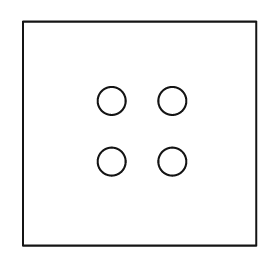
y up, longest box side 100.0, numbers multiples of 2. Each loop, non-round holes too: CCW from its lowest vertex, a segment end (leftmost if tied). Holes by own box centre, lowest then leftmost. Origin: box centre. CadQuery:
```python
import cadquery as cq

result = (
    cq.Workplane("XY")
    .moveTo(-50.0, -48.0)
    .lineTo(50.0, -48.0)
    .lineTo(50.0, 48.0)
    .lineTo(-50.0, 48.0)
    .close()
    .moveTo(-12.0, -12.0)
    .circle(6.0)
    .moveTo(14.0, -12.0)
    .circle(6.0)
    .moveTo(-12.0, 14.0)
    .circle(6.0)
    .moveTo(14.0, 14.0)
    .circle(6.0)
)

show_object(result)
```